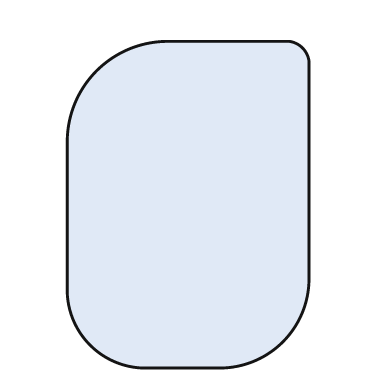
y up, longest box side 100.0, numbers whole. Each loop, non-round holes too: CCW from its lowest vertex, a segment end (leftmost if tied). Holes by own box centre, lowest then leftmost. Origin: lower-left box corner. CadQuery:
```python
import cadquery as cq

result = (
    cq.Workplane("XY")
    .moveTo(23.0, 0.0)
    .lineTo(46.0, 0.0)
    .threePointArc((66.0, 8.0), (74.0, 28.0))
    .lineTo(74.0, 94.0)
    .threePointArc((72.0, 98.0), (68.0, 100.0))
    .lineTo(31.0, 100.0)
    .threePointArc((9.0, 91.0), (0.0, 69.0))
    .lineTo(0.0, 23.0)
    .threePointArc((7.0, 7.0), (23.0, 0.0))
    .close()
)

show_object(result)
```